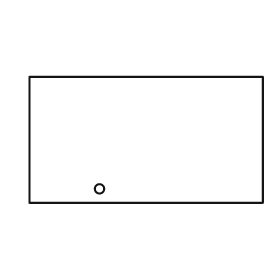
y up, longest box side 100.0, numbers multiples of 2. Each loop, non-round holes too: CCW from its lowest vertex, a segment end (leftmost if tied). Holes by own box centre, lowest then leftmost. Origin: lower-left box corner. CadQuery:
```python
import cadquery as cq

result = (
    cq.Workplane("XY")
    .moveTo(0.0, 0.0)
    .lineTo(100.0, 0.0)
    .lineTo(100.0, 54.0)
    .lineTo(0.0, 54.0)
    .close()
    .moveTo(30.0, 6.0)
    .circle(2.0)
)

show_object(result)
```